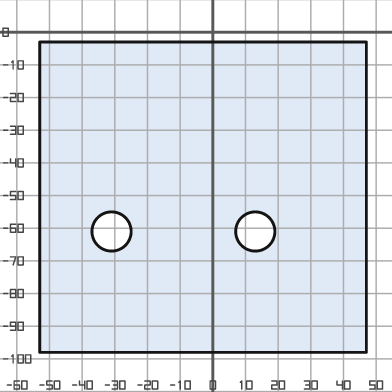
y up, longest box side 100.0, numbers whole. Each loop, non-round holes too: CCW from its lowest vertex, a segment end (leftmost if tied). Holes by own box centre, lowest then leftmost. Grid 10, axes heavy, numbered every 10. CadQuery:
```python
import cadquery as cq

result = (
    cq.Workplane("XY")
    .moveTo(-53.0, -98.0)
    .lineTo(47.0, -98.0)
    .lineTo(47.0, -3.0)
    .lineTo(-53.0, -3.0)
    .close()
    .moveTo(-31.0, -61.0)
    .circle(6.0)
    .moveTo(13.0, -61.0)
    .circle(6.0)
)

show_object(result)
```